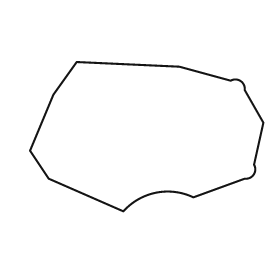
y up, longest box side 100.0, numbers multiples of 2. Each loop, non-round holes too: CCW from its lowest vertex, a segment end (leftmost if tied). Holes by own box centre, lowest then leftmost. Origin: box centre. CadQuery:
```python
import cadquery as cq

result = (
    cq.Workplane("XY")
    .moveTo(-10.0, -32.0)
    .threePointArc((4.0, -24.0), (20.0, -26.0))
    .lineTo(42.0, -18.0)
    .threePointArc((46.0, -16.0), (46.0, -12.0))
    .lineTo(50.0, 6.0)
    .lineTo(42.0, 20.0)
    .threePointArc((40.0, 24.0), (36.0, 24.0))
    .lineTo(14.0, 30.0)
    .lineTo(-30.0, 32.0)
    .lineTo(-40.0, 18.0)
    .lineTo(-50.0, -6.0)
    .lineTo(-42.0, -18.0)
    .close()
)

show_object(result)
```